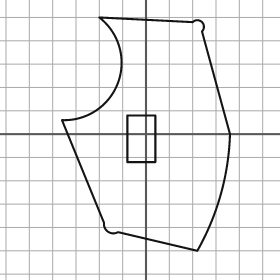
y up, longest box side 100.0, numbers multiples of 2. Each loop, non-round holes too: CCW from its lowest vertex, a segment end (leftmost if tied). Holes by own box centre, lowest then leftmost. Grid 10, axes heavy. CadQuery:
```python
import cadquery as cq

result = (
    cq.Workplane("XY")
    .moveTo(22.0, -50.0)
    .threePointArc((32.0, -26.0), (36.0, 0.0))
    .lineTo(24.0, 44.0)
    .threePointArc((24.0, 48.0), (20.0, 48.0))
    .lineTo(-20.0, 50.0)
    .threePointArc((-12.0, 22.0), (-36.0, 6.0))
    .lineTo(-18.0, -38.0)
    .threePointArc((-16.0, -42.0), (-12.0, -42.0))
    .close()
    .moveTo(-8.0, -12.0)
    .lineTo(4.0, -12.0)
    .lineTo(4.0, 8.0)
    .lineTo(-8.0, 8.0)
    .close()
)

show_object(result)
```